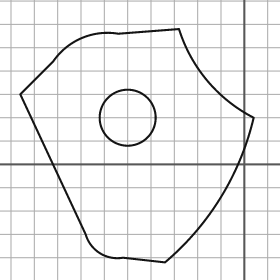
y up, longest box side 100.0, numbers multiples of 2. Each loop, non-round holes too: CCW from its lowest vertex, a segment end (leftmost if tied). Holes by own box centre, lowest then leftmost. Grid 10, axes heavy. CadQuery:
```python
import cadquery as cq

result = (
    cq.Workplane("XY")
    .moveTo(-34.0, -42.0)
    .threePointArc((-10.0, -14.0), (4.0, 20.0))
    .threePointArc((-16.0, 36.0), (-28.0, 58.0))
    .lineTo(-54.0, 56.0)
    .threePointArc((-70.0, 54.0), (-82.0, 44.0))
    .lineTo(-96.0, 30.0)
    .lineTo(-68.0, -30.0)
    .threePointArc((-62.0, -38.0), (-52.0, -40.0))
    .close()
    .moveTo(-50.0, 20.0)
    .circle(12.0)
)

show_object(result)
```